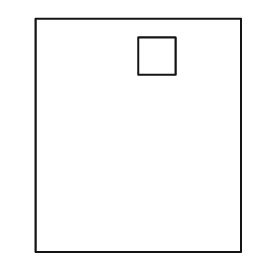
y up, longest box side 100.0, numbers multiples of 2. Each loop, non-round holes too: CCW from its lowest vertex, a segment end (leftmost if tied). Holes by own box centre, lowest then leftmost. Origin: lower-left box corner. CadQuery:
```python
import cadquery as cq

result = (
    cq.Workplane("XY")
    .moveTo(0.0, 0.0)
    .lineTo(88.0, 0.0)
    .lineTo(88.0, 100.0)
    .lineTo(0.0, 100.0)
    .close()
    .moveTo(44.0, 76.0)
    .lineTo(60.0, 76.0)
    .lineTo(60.0, 92.0)
    .lineTo(44.0, 92.0)
    .close()
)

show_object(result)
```